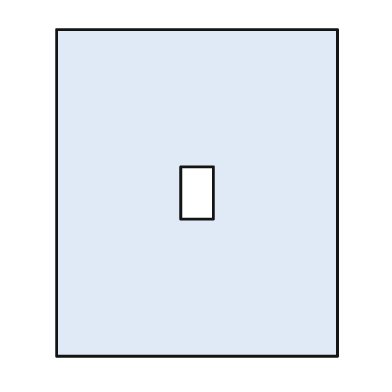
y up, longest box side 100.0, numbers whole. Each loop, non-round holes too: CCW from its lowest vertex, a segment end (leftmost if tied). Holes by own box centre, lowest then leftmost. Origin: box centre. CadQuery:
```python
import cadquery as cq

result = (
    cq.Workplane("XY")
    .moveTo(-43.0, -50.0)
    .lineTo(43.0, -50.0)
    .lineTo(43.0, 50.0)
    .lineTo(-43.0, 50.0)
    .close()
    .moveTo(-5.0, -8.0)
    .lineTo(5.0, -8.0)
    .lineTo(5.0, 8.0)
    .lineTo(-5.0, 8.0)
    .close()
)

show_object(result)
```